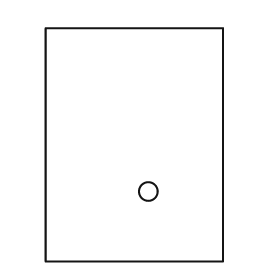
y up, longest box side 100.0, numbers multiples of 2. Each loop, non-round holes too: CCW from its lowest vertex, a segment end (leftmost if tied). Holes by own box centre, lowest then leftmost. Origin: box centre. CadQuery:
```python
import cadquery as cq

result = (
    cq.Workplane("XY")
    .moveTo(-38.0, -50.0)
    .lineTo(38.0, -50.0)
    .lineTo(38.0, 50.0)
    .lineTo(-38.0, 50.0)
    .close()
    .moveTo(6.0, -20.0)
    .circle(4.0)
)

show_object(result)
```